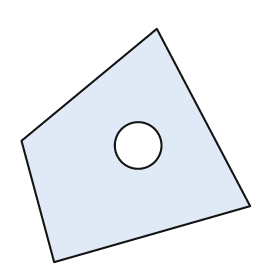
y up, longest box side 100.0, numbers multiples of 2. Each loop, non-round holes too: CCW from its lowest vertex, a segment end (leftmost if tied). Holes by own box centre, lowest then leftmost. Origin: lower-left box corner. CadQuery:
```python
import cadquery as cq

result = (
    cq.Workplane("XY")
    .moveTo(14.0, 0.0)
    .lineTo(98.0, 24.0)
    .lineTo(58.0, 100.0)
    .lineTo(0.0, 52.0)
    .close()
    .moveTo(50.0, 50.0)
    .circle(10.0)
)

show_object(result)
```